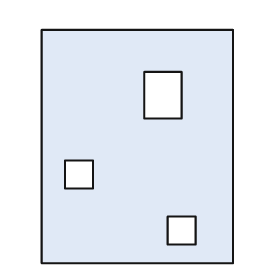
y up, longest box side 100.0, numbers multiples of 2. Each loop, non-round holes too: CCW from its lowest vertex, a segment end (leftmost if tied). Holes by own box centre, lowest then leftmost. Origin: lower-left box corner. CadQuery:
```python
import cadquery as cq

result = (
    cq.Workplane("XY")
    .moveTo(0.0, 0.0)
    .lineTo(82.0, 0.0)
    .lineTo(82.0, 100.0)
    .lineTo(0.0, 100.0)
    .close()
    .moveTo(54.0, 8.0)
    .lineTo(66.0, 8.0)
    .lineTo(66.0, 20.0)
    .lineTo(54.0, 20.0)
    .close()
    .moveTo(10.0, 32.0)
    .lineTo(22.0, 32.0)
    .lineTo(22.0, 44.0)
    .lineTo(10.0, 44.0)
    .close()
    .moveTo(44.0, 62.0)
    .lineTo(60.0, 62.0)
    .lineTo(60.0, 82.0)
    .lineTo(44.0, 82.0)
    .close()
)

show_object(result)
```